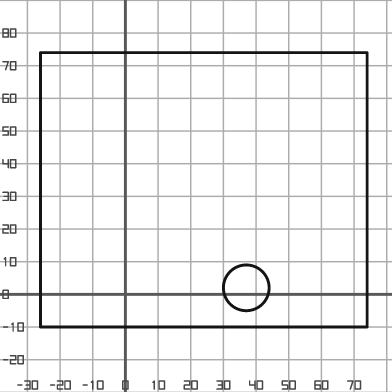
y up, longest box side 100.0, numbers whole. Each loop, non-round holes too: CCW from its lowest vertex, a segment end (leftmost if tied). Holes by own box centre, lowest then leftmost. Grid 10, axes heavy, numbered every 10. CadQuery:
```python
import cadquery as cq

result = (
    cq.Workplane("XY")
    .moveTo(-26.0, -10.0)
    .lineTo(74.0, -10.0)
    .lineTo(74.0, 74.0)
    .lineTo(-26.0, 74.0)
    .close()
    .moveTo(37.0, 2.0)
    .circle(7.0)
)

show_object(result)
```